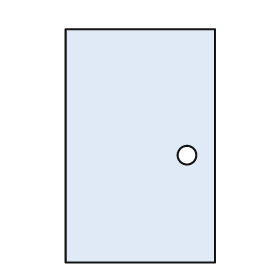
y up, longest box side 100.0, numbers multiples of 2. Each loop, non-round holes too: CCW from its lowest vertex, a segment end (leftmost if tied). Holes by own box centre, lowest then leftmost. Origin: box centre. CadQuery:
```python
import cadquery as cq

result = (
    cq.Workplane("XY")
    .moveTo(-32.0, -50.0)
    .lineTo(32.0, -50.0)
    .lineTo(32.0, 50.0)
    .lineTo(-32.0, 50.0)
    .close()
    .moveTo(20.0, -4.0)
    .circle(4.0)
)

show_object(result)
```